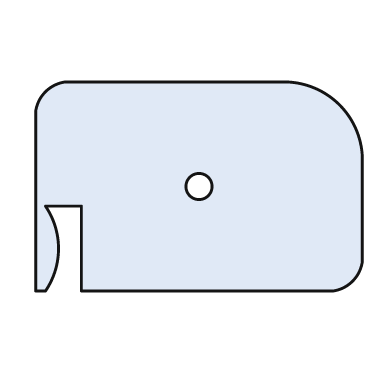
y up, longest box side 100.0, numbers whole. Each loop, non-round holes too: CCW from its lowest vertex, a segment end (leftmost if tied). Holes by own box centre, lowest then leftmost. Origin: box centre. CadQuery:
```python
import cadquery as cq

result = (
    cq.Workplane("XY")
    .moveTo(-50.0, -32.0)
    .lineTo(-47.0, -32.0)
    .threePointArc((-43.0, -19.0), (-47.0, -6.0))
    .lineTo(-36.0, -6.0)
    .lineTo(-36.0, -32.0)
    .lineTo(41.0, -32.0)
    .threePointArc((47.0, -29.0), (50.0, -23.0))
    .lineTo(50.0, 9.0)
    .threePointArc((43.0, 25.0), (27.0, 32.0))
    .lineTo(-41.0, 32.0)
    .threePointArc((-47.0, 29.0), (-50.0, 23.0))
    .close()
    .moveTo(0.0, 0.0)
    .circle(4.0)
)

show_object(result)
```